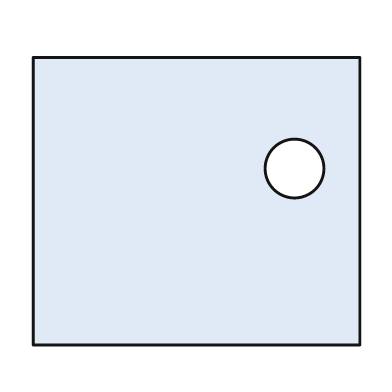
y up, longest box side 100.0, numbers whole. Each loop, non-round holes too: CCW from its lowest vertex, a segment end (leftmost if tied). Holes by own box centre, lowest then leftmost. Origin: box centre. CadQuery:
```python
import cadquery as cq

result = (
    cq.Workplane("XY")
    .moveTo(-50.0, -44.0)
    .lineTo(50.0, -44.0)
    .lineTo(50.0, 44.0)
    .lineTo(-50.0, 44.0)
    .close()
    .moveTo(30.0, 10.0)
    .circle(9.0)
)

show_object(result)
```